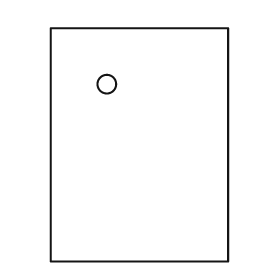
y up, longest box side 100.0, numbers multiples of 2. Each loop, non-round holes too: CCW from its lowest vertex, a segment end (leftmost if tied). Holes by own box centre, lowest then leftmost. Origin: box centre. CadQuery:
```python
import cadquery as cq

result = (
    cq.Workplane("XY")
    .moveTo(-38.0, -50.0)
    .lineTo(38.0, -50.0)
    .lineTo(38.0, 50.0)
    .lineTo(-38.0, 50.0)
    .close()
    .moveTo(-14.0, 26.0)
    .circle(4.0)
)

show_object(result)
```